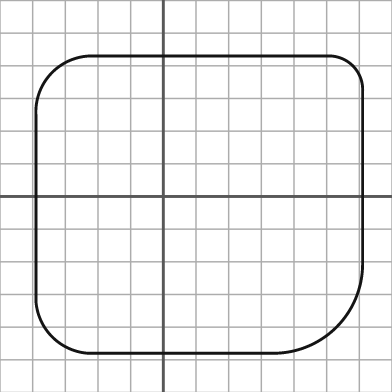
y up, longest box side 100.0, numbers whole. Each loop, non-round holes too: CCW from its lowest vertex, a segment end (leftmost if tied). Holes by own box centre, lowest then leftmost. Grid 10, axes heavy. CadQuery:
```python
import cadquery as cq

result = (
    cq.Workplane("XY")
    .moveTo(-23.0, -48.0)
    .lineTo(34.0, -48.0)
    .threePointArc((53.0, -40.0), (61.0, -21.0))
    .lineTo(61.0, 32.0)
    .threePointArc((58.0, 40.0), (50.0, 43.0))
    .lineTo(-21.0, 43.0)
    .threePointArc((-34.0, 38.0), (-39.0, 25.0))
    .lineTo(-39.0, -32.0)
    .threePointArc((-34.0, -43.0), (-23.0, -48.0))
    .close()
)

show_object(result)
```